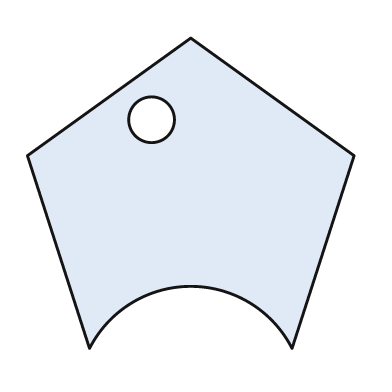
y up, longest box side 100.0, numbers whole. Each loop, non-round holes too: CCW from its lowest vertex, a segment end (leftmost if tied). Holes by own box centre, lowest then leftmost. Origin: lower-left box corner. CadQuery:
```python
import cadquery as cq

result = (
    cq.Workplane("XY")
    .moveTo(19.0, 0.0)
    .threePointArc((50.0, 19.0), (81.0, 0.0))
    .lineTo(100.0, 59.0)
    .lineTo(50.0, 95.0)
    .lineTo(0.0, 59.0)
    .close()
    .moveTo(38.0, 70.0)
    .circle(7.0)
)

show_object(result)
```